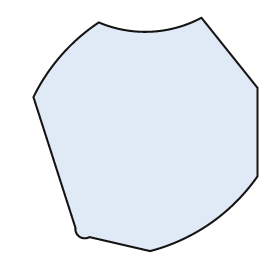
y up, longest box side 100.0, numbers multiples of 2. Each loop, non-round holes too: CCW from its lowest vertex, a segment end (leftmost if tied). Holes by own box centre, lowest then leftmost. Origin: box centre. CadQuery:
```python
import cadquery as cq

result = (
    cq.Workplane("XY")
    .moveTo(2.0, -50.0)
    .threePointArc((28.0, -38.0), (48.0, -18.0))
    .lineTo(48.0, 20.0)
    .lineTo(24.0, 50.0)
    .threePointArc((2.0, 44.0), (-20.0, 48.0))
    .threePointArc((-36.0, 34.0), (-48.0, 16.0))
    .lineTo(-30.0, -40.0)
    .threePointArc((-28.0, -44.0), (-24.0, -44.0))
    .close()
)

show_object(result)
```